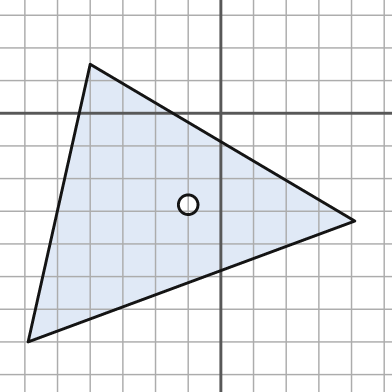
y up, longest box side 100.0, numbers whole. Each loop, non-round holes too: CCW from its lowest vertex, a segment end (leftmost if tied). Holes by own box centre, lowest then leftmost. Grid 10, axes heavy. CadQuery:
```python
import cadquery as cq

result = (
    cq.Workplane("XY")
    .moveTo(-59.0, -70.0)
    .lineTo(41.0, -33.0)
    .lineTo(-40.0, 15.0)
    .close()
    .moveTo(-10.0, -28.0)
    .circle(3.0)
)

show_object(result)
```